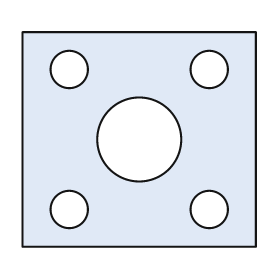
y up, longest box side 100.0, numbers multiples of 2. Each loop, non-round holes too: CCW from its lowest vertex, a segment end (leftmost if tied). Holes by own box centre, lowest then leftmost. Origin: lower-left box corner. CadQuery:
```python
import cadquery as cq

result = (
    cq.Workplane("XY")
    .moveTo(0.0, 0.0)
    .lineTo(100.0, 0.0)
    .lineTo(100.0, 92.0)
    .lineTo(0.0, 92.0)
    .close()
    .moveTo(20.0, 16.0)
    .circle(8.0)
    .moveTo(80.0, 16.0)
    .circle(8.0)
    .moveTo(50.0, 46.0)
    .circle(18.0)
    .moveTo(20.0, 76.0)
    .circle(8.0)
    .moveTo(80.0, 76.0)
    .circle(8.0)
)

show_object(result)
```